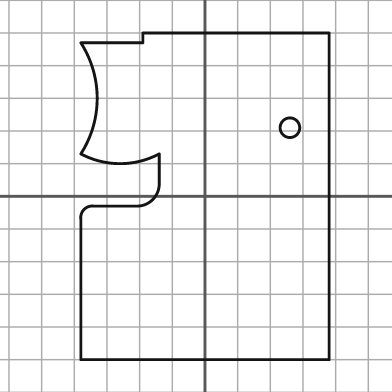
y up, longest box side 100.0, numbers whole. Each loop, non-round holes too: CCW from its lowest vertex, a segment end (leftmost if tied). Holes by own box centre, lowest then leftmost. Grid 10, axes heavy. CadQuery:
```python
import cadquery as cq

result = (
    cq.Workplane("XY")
    .moveTo(-38.0, -50.0)
    .lineTo(38.0, -50.0)
    .lineTo(38.0, 50.0)
    .lineTo(-19.0, 50.0)
    .lineTo(-19.0, 47.0)
    .lineTo(-38.0, 47.0)
    .threePointArc((-33.0, 30.0), (-38.0, 13.0))
    .threePointArc((-26.0, 10.0), (-14.0, 13.0))
    .lineTo(-14.0, 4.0)
    .threePointArc((-16.0, -1.0), (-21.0, -3.0))
    .lineTo(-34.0, -3.0)
    .threePointArc((-37.0, -4.0), (-38.0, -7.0))
    .close()
    .moveTo(26.0, 21.0)
    .circle(3.0)
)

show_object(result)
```